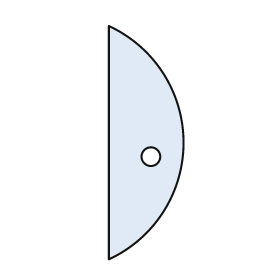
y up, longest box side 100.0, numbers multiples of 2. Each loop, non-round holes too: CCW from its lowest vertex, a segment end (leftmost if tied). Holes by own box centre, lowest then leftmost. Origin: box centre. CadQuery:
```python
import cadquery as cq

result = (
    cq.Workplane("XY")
    .moveTo(-16.0, -50.0)
    .threePointArc((16.0, 0.0), (-16.0, 50.0))
    .close()
    .moveTo(2.0, -6.0)
    .circle(4.0)
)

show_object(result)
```